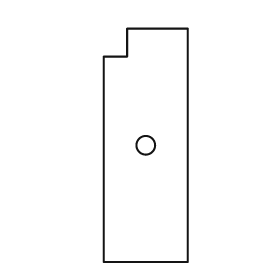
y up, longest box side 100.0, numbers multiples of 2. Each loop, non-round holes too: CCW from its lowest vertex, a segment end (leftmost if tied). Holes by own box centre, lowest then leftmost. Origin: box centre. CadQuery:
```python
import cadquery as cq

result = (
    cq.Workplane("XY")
    .moveTo(-18.0, -50.0)
    .lineTo(18.0, -50.0)
    .lineTo(18.0, 50.0)
    .lineTo(-8.0, 50.0)
    .lineTo(-8.0, 38.0)
    .lineTo(-18.0, 38.0)
    .close()
    .moveTo(0.0, 0.0)
    .circle(4.0)
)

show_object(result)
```